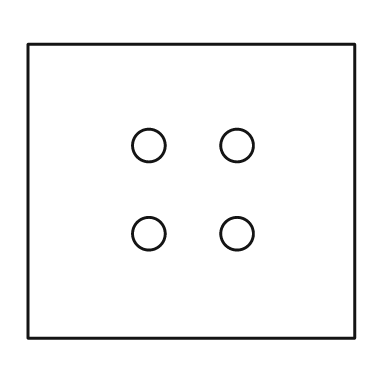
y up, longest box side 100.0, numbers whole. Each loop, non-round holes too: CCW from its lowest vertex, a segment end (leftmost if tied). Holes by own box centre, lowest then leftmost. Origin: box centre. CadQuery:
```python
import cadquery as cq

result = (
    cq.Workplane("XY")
    .moveTo(-50.0, -45.0)
    .lineTo(50.0, -45.0)
    .lineTo(50.0, 45.0)
    .lineTo(-50.0, 45.0)
    .close()
    .moveTo(-13.0, -13.0)
    .circle(5.0)
    .moveTo(14.0, -13.0)
    .circle(5.0)
    .moveTo(-13.0, 14.0)
    .circle(5.0)
    .moveTo(14.0, 14.0)
    .circle(5.0)
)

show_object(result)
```